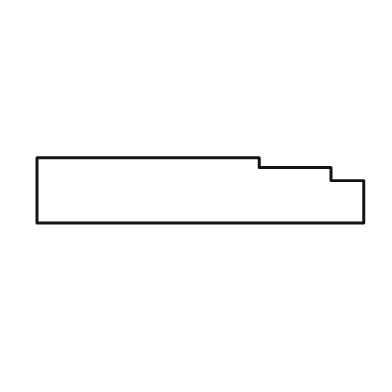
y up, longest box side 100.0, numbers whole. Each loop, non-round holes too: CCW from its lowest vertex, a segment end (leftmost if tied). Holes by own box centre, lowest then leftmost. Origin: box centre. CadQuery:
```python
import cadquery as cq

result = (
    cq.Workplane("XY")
    .moveTo(-50.0, -10.0)
    .lineTo(50.0, -10.0)
    .lineTo(50.0, 3.0)
    .lineTo(40.0, 3.0)
    .lineTo(40.0, 7.0)
    .lineTo(18.0, 7.0)
    .lineTo(18.0, 10.0)
    .lineTo(-50.0, 10.0)
    .close()
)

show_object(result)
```